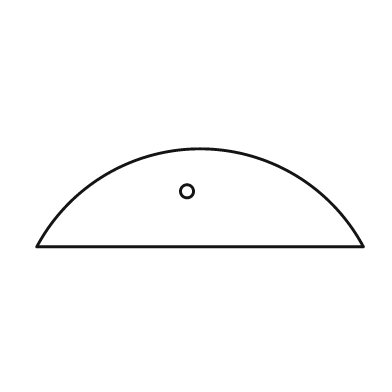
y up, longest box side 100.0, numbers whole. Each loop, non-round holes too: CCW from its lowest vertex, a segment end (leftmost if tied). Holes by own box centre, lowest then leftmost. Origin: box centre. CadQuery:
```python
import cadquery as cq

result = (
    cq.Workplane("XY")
    .moveTo(-50.0, -15.0)
    .lineTo(50.0, -15.0)
    .threePointArc((0.0, 15.0), (-50.0, -15.0))
    .close()
    .moveTo(-4.0, 2.0)
    .circle(2.0)
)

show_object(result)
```